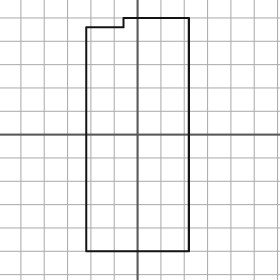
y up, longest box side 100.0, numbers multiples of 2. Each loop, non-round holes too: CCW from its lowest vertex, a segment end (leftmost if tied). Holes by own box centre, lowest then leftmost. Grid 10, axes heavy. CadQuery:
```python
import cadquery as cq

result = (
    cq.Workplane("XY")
    .moveTo(-22.0, -50.0)
    .lineTo(22.0, -50.0)
    .lineTo(22.0, 50.0)
    .lineTo(-6.0, 50.0)
    .lineTo(-6.0, 46.0)
    .lineTo(-22.0, 46.0)
    .close()
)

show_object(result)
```